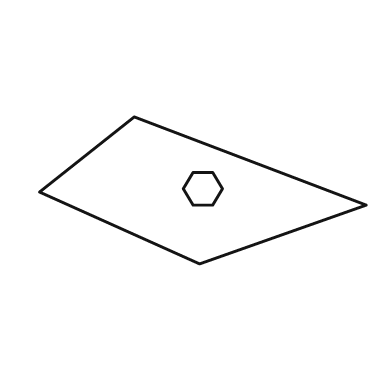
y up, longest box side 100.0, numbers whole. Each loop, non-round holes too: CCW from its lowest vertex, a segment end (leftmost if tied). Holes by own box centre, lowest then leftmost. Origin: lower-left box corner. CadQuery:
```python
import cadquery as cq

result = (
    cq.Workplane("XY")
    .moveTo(49.0, 0.0)
    .lineTo(100.0, 18.0)
    .lineTo(29.0, 45.0)
    .lineTo(0.0, 22.0)
    .close()
    .moveTo(47.0, 18.0)
    .lineTo(53.0, 18.0)
    .lineTo(56.0, 23.0)
    .lineTo(53.0, 28.0)
    .lineTo(47.0, 28.0)
    .lineTo(44.0, 23.0)
    .close()
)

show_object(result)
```